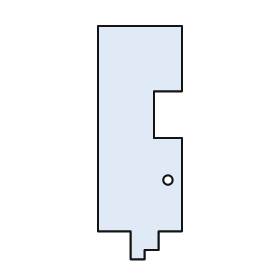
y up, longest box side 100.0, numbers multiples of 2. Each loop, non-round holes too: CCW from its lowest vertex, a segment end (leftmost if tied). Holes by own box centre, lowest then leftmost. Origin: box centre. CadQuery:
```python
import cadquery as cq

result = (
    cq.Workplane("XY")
    .moveTo(-4.0, -50.0)
    .lineTo(2.0, -50.0)
    .lineTo(2.0, -46.0)
    .lineTo(8.0, -46.0)
    .lineTo(8.0, -38.0)
    .lineTo(18.0, -38.0)
    .lineTo(18.0, 2.0)
    .lineTo(6.0, 2.0)
    .lineTo(6.0, 22.0)
    .lineTo(18.0, 22.0)
    .lineTo(18.0, 50.0)
    .lineTo(-18.0, 50.0)
    .lineTo(-18.0, -38.0)
    .lineTo(-4.0, -38.0)
    .close()
    .moveTo(12.0, -16.0)
    .circle(2.0)
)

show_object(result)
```